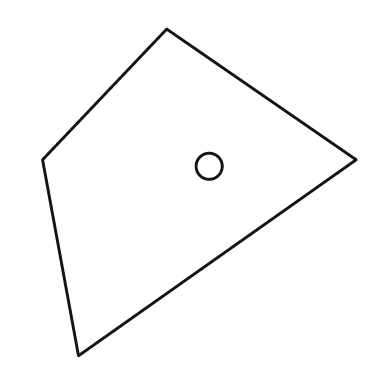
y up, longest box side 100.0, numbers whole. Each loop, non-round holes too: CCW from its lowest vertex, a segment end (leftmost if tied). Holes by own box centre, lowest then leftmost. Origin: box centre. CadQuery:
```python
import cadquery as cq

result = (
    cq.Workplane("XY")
    .moveTo(-37.0, -50.0)
    .lineTo(48.0, 10.0)
    .lineTo(-10.0, 50.0)
    .lineTo(-48.0, 10.0)
    .close()
    .moveTo(3.0, 8.0)
    .circle(4.0)
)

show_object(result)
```